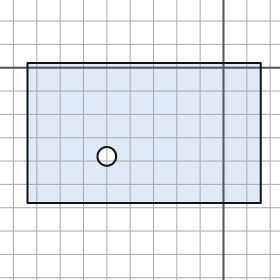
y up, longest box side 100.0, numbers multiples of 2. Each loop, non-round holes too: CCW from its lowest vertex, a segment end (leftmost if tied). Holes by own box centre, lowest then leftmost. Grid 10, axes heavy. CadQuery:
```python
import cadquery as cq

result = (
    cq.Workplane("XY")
    .moveTo(-84.0, -58.0)
    .lineTo(16.0, -58.0)
    .lineTo(16.0, 2.0)
    .lineTo(-84.0, 2.0)
    .close()
    .moveTo(-50.0, -38.0)
    .circle(4.0)
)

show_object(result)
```